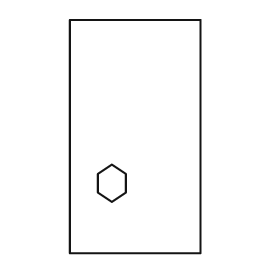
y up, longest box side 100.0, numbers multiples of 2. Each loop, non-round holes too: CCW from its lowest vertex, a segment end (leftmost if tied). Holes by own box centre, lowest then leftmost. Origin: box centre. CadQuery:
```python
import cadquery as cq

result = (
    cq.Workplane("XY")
    .moveTo(-28.0, -50.0)
    .lineTo(28.0, -50.0)
    .lineTo(28.0, 50.0)
    .lineTo(-28.0, 50.0)
    .close()
    .moveTo(-10.0, -28.0)
    .lineTo(-4.0, -24.0)
    .lineTo(-4.0, -16.0)
    .lineTo(-10.0, -12.0)
    .lineTo(-16.0, -16.0)
    .lineTo(-16.0, -24.0)
    .close()
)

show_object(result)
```